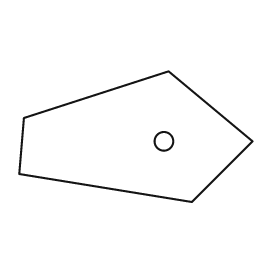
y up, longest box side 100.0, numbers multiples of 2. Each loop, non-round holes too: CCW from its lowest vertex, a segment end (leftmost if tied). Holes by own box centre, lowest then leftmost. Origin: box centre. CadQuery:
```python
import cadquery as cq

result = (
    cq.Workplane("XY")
    .moveTo(24.0, -28.0)
    .lineTo(50.0, -2.0)
    .lineTo(14.0, 28.0)
    .lineTo(-48.0, 8.0)
    .lineTo(-50.0, -16.0)
    .close()
    .moveTo(12.0, -2.0)
    .circle(4.0)
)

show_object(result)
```